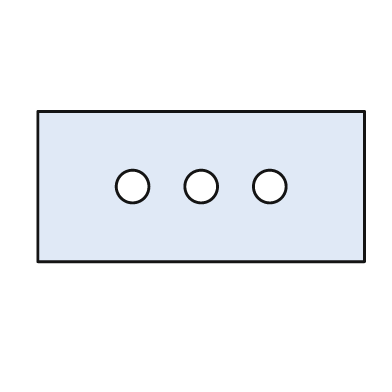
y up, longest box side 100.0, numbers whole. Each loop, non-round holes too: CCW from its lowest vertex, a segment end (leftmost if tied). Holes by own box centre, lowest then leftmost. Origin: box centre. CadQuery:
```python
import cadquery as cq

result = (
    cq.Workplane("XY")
    .moveTo(-50.0, -23.0)
    .lineTo(50.0, -23.0)
    .lineTo(50.0, 23.0)
    .lineTo(-50.0, 23.0)
    .close()
    .moveTo(-21.0, 0.0)
    .circle(5.0)
    .moveTo(0.0, 0.0)
    .circle(5.0)
    .moveTo(21.0, 0.0)
    .circle(5.0)
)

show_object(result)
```